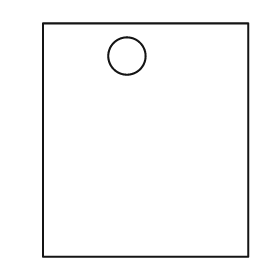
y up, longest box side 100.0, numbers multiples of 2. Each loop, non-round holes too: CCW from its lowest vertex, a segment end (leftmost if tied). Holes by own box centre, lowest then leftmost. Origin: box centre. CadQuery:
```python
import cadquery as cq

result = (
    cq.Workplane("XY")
    .moveTo(-44.0, -50.0)
    .lineTo(44.0, -50.0)
    .lineTo(44.0, 50.0)
    .lineTo(-44.0, 50.0)
    .close()
    .moveTo(-8.0, 36.0)
    .circle(8.0)
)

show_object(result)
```